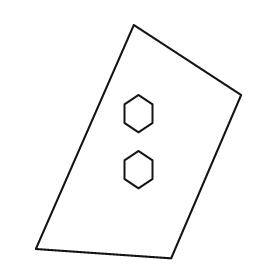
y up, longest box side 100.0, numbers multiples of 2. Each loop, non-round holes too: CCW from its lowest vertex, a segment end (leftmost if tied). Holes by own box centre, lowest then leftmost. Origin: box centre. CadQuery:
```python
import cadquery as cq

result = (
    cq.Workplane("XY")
    .moveTo(14.0, -50.0)
    .lineTo(44.0, 20.0)
    .lineTo(-2.0, 50.0)
    .lineTo(-44.0, -46.0)
    .close()
    .moveTo(0.0, -20.0)
    .lineTo(6.0, -16.0)
    .lineTo(6.0, -8.0)
    .lineTo(0.0, -4.0)
    .lineTo(-6.0, -8.0)
    .lineTo(-6.0, -16.0)
    .close()
    .moveTo(0.0, 4.0)
    .lineTo(6.0, 8.0)
    .lineTo(6.0, 16.0)
    .lineTo(0.0, 20.0)
    .lineTo(-6.0, 16.0)
    .lineTo(-6.0, 8.0)
    .close()
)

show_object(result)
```